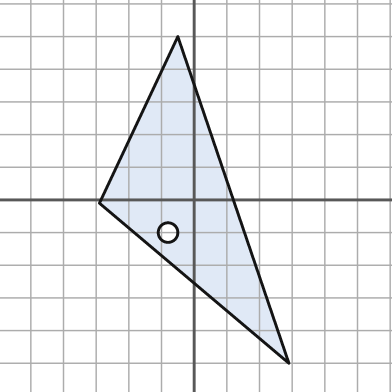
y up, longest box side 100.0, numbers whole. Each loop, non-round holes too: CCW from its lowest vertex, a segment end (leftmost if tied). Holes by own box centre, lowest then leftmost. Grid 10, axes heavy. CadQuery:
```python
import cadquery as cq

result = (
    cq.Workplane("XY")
    .moveTo(29.0, -50.0)
    .lineTo(-5.0, 50.0)
    .lineTo(-29.0, -1.0)
    .close()
    .moveTo(-8.0, -10.0)
    .circle(3.0)
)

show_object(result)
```